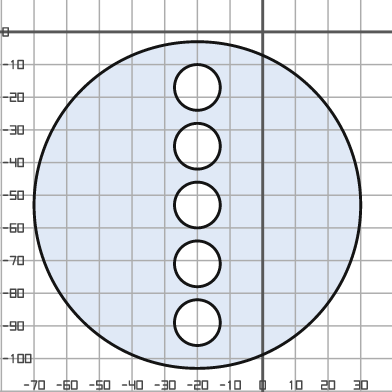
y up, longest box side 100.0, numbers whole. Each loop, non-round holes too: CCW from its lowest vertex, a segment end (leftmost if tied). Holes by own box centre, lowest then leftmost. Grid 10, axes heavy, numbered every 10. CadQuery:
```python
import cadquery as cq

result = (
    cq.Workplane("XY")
    .moveTo(-20.0, -53.0)
    .circle(50.0)
    .moveTo(-20.0, -89.0)
    .circle(7.0)
    .moveTo(-20.0, -71.0)
    .circle(7.0)
    .moveTo(-20.0, -53.0)
    .circle(7.0)
    .moveTo(-20.0, -35.0)
    .circle(7.0)
    .moveTo(-20.0, -17.0)
    .circle(7.0)
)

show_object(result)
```